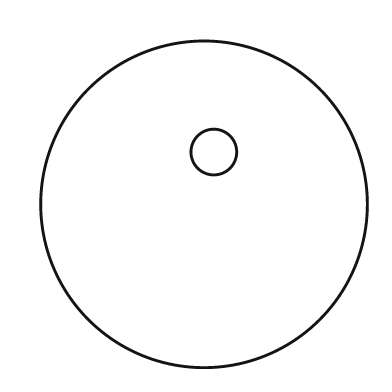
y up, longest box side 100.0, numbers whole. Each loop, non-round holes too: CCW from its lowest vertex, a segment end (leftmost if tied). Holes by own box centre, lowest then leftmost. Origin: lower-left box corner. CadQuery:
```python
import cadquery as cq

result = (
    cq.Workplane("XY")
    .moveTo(50.0, 50.0)
    .circle(50.0)
    .moveTo(53.0, 66.0)
    .circle(7.0)
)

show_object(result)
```